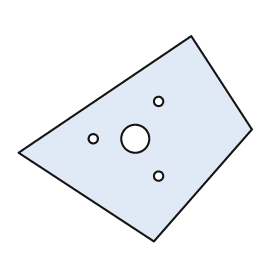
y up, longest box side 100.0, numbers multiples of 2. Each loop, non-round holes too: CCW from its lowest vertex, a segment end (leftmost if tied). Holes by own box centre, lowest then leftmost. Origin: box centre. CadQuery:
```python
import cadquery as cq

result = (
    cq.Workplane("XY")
    .moveTo(8.0, -44.0)
    .lineTo(50.0, 4.0)
    .lineTo(24.0, 44.0)
    .lineTo(-50.0, -6.0)
    .close()
    .moveTo(10.0, -16.0)
    .circle(2.0)
    .moveTo(-18.0, 0.0)
    .circle(2.0)
    .moveTo(0.0, 0.0)
    .circle(6.0)
    .moveTo(10.0, 16.0)
    .circle(2.0)
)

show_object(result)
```